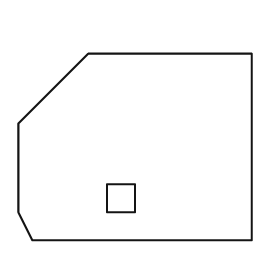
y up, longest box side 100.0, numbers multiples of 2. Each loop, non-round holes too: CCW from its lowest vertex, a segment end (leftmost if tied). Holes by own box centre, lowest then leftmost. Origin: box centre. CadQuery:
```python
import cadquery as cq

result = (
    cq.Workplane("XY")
    .moveTo(-44.0, -40.0)
    .lineTo(50.0, -40.0)
    .lineTo(50.0, 40.0)
    .lineTo(-20.0, 40.0)
    .lineTo(-50.0, 10.0)
    .lineTo(-50.0, -28.0)
    .close()
    .moveTo(-12.0, -28.0)
    .lineTo(0.0, -28.0)
    .lineTo(0.0, -16.0)
    .lineTo(-12.0, -16.0)
    .close()
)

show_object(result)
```